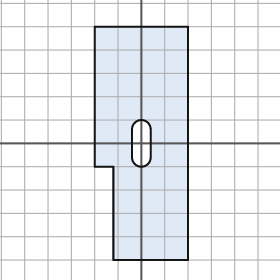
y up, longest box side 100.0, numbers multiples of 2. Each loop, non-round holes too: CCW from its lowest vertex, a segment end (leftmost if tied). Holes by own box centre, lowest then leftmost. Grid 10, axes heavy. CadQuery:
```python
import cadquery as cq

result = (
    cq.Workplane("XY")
    .moveTo(-12.0, -50.0)
    .lineTo(20.0, -50.0)
    .lineTo(20.0, 50.0)
    .lineTo(-20.0, 50.0)
    .lineTo(-20.0, -10.0)
    .lineTo(-12.0, -10.0)
    .close()
    .moveTo(-4.0, -6.0)
    .threePointArc((0.0, -10.0), (4.0, -6.0))
    .lineTo(4.0, 6.0)
    .threePointArc((0.0, 10.0), (-4.0, 6.0))
    .close()
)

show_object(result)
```